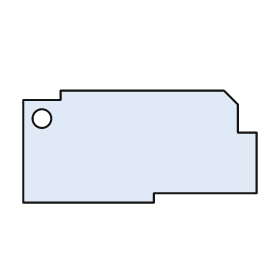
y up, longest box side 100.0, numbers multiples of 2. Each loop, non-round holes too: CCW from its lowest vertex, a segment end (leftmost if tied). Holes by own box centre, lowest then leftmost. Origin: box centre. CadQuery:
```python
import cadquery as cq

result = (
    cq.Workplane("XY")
    .moveTo(-50.0, -24.0)
    .lineTo(6.0, -24.0)
    .lineTo(6.0, -20.0)
    .lineTo(50.0, -20.0)
    .lineTo(50.0, 6.0)
    .lineTo(42.0, 6.0)
    .lineTo(42.0, 18.0)
    .lineTo(36.0, 24.0)
    .lineTo(-34.0, 24.0)
    .lineTo(-34.0, 20.0)
    .lineTo(-50.0, 20.0)
    .close()
    .moveTo(-42.0, 12.0)
    .circle(4.0)
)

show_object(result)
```